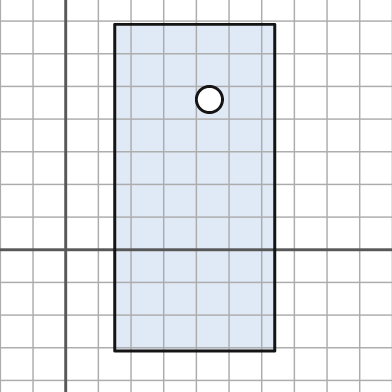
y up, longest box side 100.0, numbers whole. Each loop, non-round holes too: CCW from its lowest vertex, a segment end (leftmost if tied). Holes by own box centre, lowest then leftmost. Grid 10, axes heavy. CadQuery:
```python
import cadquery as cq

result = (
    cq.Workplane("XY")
    .moveTo(15.0, -31.0)
    .lineTo(64.0, -31.0)
    .lineTo(64.0, 69.0)
    .lineTo(15.0, 69.0)
    .close()
    .moveTo(44.0, 46.0)
    .circle(4.0)
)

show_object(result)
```